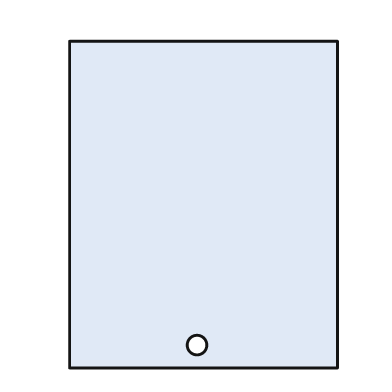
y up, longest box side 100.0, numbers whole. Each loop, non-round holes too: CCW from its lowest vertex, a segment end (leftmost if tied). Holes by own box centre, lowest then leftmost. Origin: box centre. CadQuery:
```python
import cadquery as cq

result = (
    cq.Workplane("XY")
    .moveTo(-41.0, -50.0)
    .lineTo(41.0, -50.0)
    .lineTo(41.0, 50.0)
    .lineTo(-41.0, 50.0)
    .close()
    .moveTo(-2.0, -43.0)
    .circle(3.0)
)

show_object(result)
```